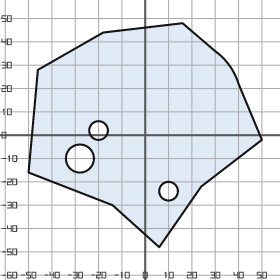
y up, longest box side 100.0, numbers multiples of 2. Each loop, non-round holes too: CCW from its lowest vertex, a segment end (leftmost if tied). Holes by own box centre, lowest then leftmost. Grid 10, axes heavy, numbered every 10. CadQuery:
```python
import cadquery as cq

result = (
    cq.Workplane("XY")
    .moveTo(6.0, -48.0)
    .lineTo(24.0, -22.0)
    .lineTo(50.0, -2.0)
    .lineTo(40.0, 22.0)
    .threePointArc((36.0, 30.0), (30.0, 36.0))
    .lineTo(16.0, 48.0)
    .lineTo(-18.0, 44.0)
    .lineTo(-46.0, 28.0)
    .lineTo(-50.0, -16.0)
    .lineTo(-14.0, -30.0)
    .close()
    .moveTo(10.0, -24.0)
    .circle(4.0)
    .moveTo(-28.0, -10.0)
    .circle(6.0)
    .moveTo(-20.0, 2.0)
    .circle(4.0)
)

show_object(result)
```